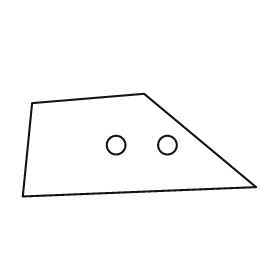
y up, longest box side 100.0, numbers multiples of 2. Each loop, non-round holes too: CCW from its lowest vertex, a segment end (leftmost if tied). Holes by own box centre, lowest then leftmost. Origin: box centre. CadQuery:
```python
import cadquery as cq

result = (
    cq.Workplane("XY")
    .moveTo(-50.0, -22.0)
    .lineTo(50.0, -18.0)
    .lineTo(2.0, 22.0)
    .lineTo(-46.0, 18.0)
    .close()
    .moveTo(-10.0, 0.0)
    .circle(4.0)
    .moveTo(12.0, 0.0)
    .circle(4.0)
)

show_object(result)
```